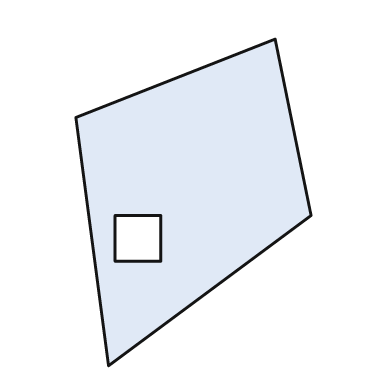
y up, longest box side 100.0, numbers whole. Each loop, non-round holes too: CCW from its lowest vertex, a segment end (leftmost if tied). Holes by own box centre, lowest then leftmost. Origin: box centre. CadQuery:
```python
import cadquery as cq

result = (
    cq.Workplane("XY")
    .moveTo(-26.0, -50.0)
    .lineTo(36.0, -4.0)
    .lineTo(25.0, 50.0)
    .lineTo(-36.0, 26.0)
    .close()
    .moveTo(-24.0, -18.0)
    .lineTo(-10.0, -18.0)
    .lineTo(-10.0, -4.0)
    .lineTo(-24.0, -4.0)
    .close()
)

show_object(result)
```